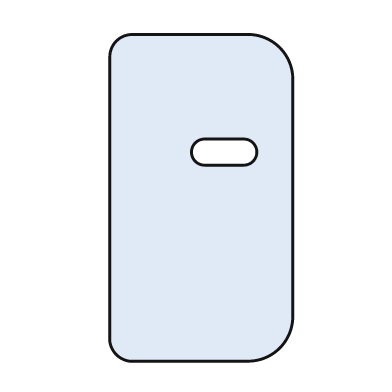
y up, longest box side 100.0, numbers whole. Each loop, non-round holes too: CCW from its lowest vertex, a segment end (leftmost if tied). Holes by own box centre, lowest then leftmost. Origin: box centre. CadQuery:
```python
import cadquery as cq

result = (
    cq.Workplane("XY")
    .moveTo(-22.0, -50.0)
    .lineTo(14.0, -50.0)
    .threePointArc((24.0, -46.0), (28.0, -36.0))
    .lineTo(28.0, 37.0)
    .threePointArc((24.0, 46.0), (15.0, 50.0))
    .lineTo(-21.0, 50.0)
    .threePointArc((-26.0, 48.0), (-28.0, 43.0))
    .lineTo(-28.0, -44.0)
    .threePointArc((-26.0, -48.0), (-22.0, -50.0))
    .close()
    .moveTo(1.0, 10.0)
    .lineTo(13.0, 10.0)
    .threePointArc((17.0, 14.0), (13.0, 18.0))
    .lineTo(1.0, 18.0)
    .threePointArc((-3.0, 14.0), (1.0, 10.0))
    .close()
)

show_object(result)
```